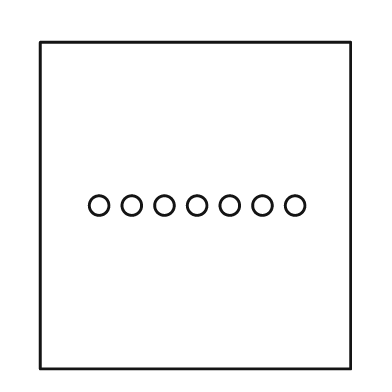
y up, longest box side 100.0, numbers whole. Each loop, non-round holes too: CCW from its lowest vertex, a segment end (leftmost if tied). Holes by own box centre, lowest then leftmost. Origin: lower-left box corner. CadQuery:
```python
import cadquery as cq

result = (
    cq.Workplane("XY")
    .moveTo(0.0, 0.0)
    .lineTo(95.0, 0.0)
    .lineTo(95.0, 100.0)
    .lineTo(0.0, 100.0)
    .close()
    .moveTo(18.0, 50.0)
    .circle(3.0)
    .moveTo(28.0, 50.0)
    .circle(3.0)
    .moveTo(38.0, 50.0)
    .circle(3.0)
    .moveTo(48.0, 50.0)
    .circle(3.0)
    .moveTo(58.0, 50.0)
    .circle(3.0)
    .moveTo(68.0, 50.0)
    .circle(3.0)
    .moveTo(78.0, 50.0)
    .circle(3.0)
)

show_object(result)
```